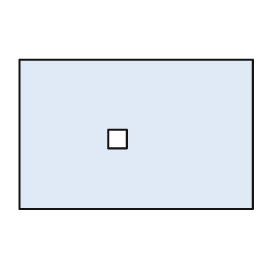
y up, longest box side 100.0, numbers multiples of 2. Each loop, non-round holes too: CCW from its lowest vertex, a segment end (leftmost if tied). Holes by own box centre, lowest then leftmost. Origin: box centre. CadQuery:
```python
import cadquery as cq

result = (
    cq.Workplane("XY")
    .moveTo(-50.0, -32.0)
    .lineTo(50.0, -32.0)
    .lineTo(50.0, 32.0)
    .lineTo(-50.0, 32.0)
    .close()
    .moveTo(-12.0, -6.0)
    .lineTo(-4.0, -6.0)
    .lineTo(-4.0, 2.0)
    .lineTo(-12.0, 2.0)
    .close()
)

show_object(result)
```